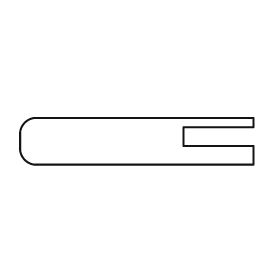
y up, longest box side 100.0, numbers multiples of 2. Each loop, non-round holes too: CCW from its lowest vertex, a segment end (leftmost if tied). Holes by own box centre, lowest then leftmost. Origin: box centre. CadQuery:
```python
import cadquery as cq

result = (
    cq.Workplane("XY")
    .moveTo(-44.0, -10.0)
    .lineTo(50.0, -10.0)
    .lineTo(50.0, -2.0)
    .lineTo(20.0, -2.0)
    .lineTo(20.0, 6.0)
    .lineTo(50.0, 6.0)
    .lineTo(50.0, 10.0)
    .lineTo(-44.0, 10.0)
    .threePointArc((-48.0, 8.0), (-50.0, 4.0))
    .lineTo(-50.0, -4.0)
    .threePointArc((-48.0, -8.0), (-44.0, -10.0))
    .close()
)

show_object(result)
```